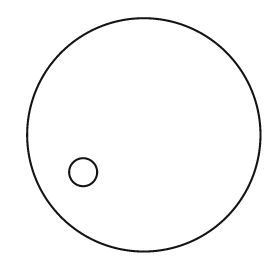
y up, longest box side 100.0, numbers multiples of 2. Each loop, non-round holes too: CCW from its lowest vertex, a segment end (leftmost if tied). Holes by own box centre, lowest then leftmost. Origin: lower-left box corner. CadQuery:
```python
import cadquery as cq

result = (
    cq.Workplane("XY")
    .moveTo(50.0, 50.0)
    .circle(50.0)
    .moveTo(24.0, 34.0)
    .circle(6.0)
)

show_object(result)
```